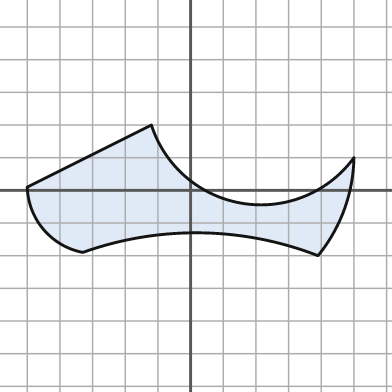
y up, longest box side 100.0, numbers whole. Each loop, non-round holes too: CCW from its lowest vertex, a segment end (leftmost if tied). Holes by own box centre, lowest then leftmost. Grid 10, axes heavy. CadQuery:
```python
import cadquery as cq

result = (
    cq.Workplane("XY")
    .moveTo(39.0, -20.0)
    .threePointArc((47.0, -6.0), (50.0, 10.0))
    .threePointArc((16.0, -4.0), (-12.0, 20.0))
    .lineTo(-50.0, 1.0)
    .threePointArc((-45.0, -12.0), (-33.0, -19.0))
    .threePointArc((3.0, -13.0), (39.0, -20.0))
    .close()
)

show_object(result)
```